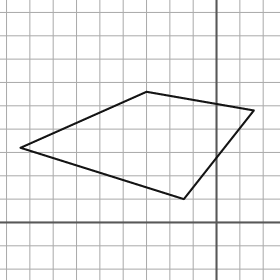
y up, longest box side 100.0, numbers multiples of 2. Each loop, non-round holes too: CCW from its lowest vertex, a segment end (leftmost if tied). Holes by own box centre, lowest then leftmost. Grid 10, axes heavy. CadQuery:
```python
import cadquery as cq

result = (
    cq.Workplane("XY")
    .moveTo(-14.0, 10.0)
    .lineTo(16.0, 48.0)
    .lineTo(-30.0, 56.0)
    .lineTo(-84.0, 32.0)
    .close()
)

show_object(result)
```